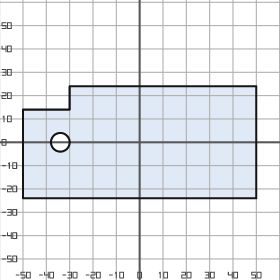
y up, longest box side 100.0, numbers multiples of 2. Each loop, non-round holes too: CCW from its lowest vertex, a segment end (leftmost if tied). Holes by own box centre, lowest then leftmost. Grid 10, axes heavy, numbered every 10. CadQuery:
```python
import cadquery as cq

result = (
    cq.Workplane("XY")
    .moveTo(-50.0, -24.0)
    .lineTo(50.0, -24.0)
    .lineTo(50.0, 24.0)
    .lineTo(-30.0, 24.0)
    .lineTo(-30.0, 14.0)
    .lineTo(-50.0, 14.0)
    .close()
    .moveTo(-34.0, 0.0)
    .circle(4.0)
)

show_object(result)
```